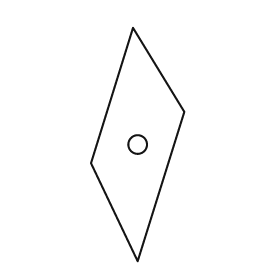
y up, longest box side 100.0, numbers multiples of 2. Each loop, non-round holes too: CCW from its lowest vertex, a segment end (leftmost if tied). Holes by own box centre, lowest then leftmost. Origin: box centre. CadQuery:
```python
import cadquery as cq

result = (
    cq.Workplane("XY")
    .moveTo(0.0, -50.0)
    .lineTo(20.0, 14.0)
    .lineTo(-2.0, 50.0)
    .lineTo(-20.0, -8.0)
    .close()
    .moveTo(0.0, 0.0)
    .circle(4.0)
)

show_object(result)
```